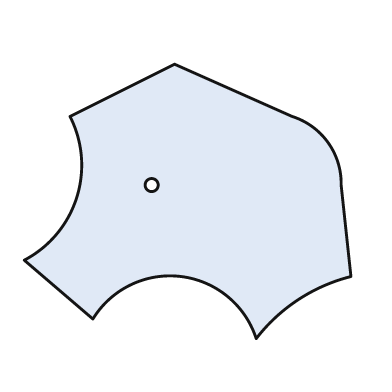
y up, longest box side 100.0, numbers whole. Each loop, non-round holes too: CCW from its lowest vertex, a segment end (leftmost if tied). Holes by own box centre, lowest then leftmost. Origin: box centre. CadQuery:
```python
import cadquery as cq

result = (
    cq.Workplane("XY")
    .moveTo(21.0, -42.0)
    .threePointArc((34.0, -30.0), (50.0, -23.0))
    .lineTo(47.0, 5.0)
    .threePointArc((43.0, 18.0), (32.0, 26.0))
    .lineTo(-4.0, 42.0)
    .lineTo(-36.0, 26.0)
    .threePointArc((-34.0, 1.0), (-50.0, -18.0))
    .lineTo(-29.0, -36.0)
    .threePointArc((-2.0, -23.0), (21.0, -42.0))
    .close()
    .moveTo(-11.0, 5.0)
    .circle(2.0)
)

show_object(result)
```